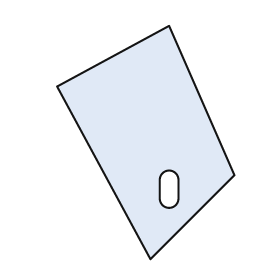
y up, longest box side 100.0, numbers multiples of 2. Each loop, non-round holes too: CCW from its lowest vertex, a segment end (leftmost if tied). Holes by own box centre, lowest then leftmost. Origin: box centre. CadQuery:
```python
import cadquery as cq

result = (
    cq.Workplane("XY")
    .moveTo(2.0, -50.0)
    .lineTo(38.0, -14.0)
    .lineTo(10.0, 50.0)
    .lineTo(-38.0, 24.0)
    .close()
    .moveTo(6.0, -24.0)
    .threePointArc((10.0, -28.0), (14.0, -24.0))
    .lineTo(14.0, -16.0)
    .threePointArc((10.0, -12.0), (6.0, -16.0))
    .close()
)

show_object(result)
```